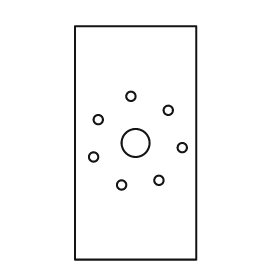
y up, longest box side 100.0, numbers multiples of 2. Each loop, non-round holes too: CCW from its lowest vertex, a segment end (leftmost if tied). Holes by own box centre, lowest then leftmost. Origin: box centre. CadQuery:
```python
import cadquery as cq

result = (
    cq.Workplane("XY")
    .moveTo(-26.0, -50.0)
    .lineTo(26.0, -50.0)
    .lineTo(26.0, 50.0)
    .lineTo(-26.0, 50.0)
    .close()
    .moveTo(-6.0, -18.0)
    .circle(2.0)
    .moveTo(10.0, -16.0)
    .circle(2.0)
    .moveTo(-18.0, -6.0)
    .circle(2.0)
    .moveTo(20.0, -2.0)
    .circle(2.0)
    .moveTo(0.0, 0.0)
    .circle(6.0)
    .moveTo(-16.0, 10.0)
    .circle(2.0)
    .moveTo(14.0, 14.0)
    .circle(2.0)
    .moveTo(-2.0, 20.0)
    .circle(2.0)
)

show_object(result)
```